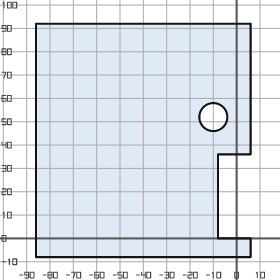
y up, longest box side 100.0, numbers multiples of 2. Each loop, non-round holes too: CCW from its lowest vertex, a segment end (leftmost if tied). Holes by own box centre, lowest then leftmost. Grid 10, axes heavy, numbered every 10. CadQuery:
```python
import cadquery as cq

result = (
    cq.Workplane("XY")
    .moveTo(-86.0, -8.0)
    .lineTo(6.0, -8.0)
    .lineTo(6.0, 0.0)
    .lineTo(-8.0, 0.0)
    .lineTo(-8.0, 36.0)
    .lineTo(6.0, 36.0)
    .lineTo(6.0, 92.0)
    .lineTo(-86.0, 92.0)
    .close()
    .moveTo(-10.0, 52.0)
    .circle(6.0)
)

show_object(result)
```